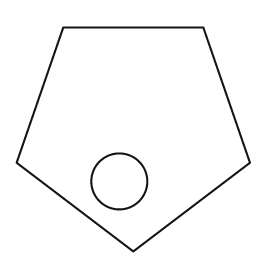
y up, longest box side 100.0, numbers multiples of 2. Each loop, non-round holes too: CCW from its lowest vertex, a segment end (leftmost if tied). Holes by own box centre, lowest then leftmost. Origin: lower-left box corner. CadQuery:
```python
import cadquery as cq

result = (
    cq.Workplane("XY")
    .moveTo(50.0, 0.0)
    .lineTo(100.0, 38.0)
    .lineTo(80.0, 96.0)
    .lineTo(20.0, 96.0)
    .lineTo(0.0, 38.0)
    .close()
    .moveTo(44.0, 30.0)
    .circle(12.0)
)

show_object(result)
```